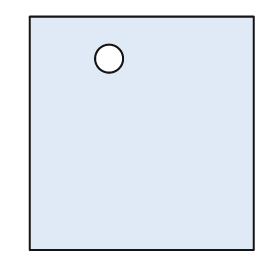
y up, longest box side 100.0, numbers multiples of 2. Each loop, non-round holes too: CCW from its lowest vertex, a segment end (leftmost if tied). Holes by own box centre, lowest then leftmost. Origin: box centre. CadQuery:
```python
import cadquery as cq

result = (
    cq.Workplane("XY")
    .moveTo(-48.0, -50.0)
    .lineTo(48.0, -50.0)
    .lineTo(48.0, 50.0)
    .lineTo(-48.0, 50.0)
    .close()
    .moveTo(-14.0, 32.0)
    .circle(6.0)
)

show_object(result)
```